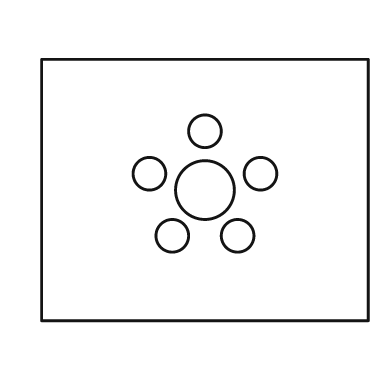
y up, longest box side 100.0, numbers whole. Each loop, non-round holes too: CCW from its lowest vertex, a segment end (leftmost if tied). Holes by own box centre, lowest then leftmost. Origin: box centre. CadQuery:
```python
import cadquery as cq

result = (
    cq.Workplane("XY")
    .moveTo(-50.0, -40.0)
    .lineTo(50.0, -40.0)
    .lineTo(50.0, 40.0)
    .lineTo(-50.0, 40.0)
    .close()
    .moveTo(-10.0, -14.0)
    .circle(5.0)
    .moveTo(10.0, -14.0)
    .circle(5.0)
    .moveTo(0.0, 0.0)
    .circle(9.0)
    .moveTo(-17.0, 5.0)
    .circle(5.0)
    .moveTo(17.0, 5.0)
    .circle(5.0)
    .moveTo(0.0, 18.0)
    .circle(5.0)
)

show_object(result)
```